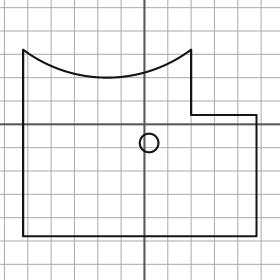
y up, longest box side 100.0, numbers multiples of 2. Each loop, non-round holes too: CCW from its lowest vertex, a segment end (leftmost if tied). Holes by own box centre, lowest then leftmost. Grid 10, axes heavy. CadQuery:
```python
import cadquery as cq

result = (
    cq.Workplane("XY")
    .moveTo(-52.0, -48.0)
    .lineTo(48.0, -48.0)
    .lineTo(48.0, 4.0)
    .lineTo(20.0, 4.0)
    .lineTo(20.0, 32.0)
    .threePointArc((-16.0, 20.0), (-52.0, 32.0))
    .close()
    .moveTo(2.0, -8.0)
    .circle(4.0)
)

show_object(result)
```